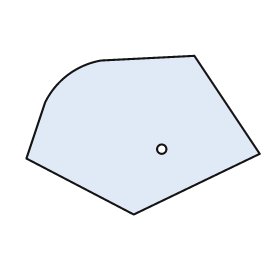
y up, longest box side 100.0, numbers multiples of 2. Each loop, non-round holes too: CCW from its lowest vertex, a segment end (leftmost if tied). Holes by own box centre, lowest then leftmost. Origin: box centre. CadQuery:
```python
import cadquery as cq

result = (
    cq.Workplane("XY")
    .moveTo(-4.0, -34.0)
    .lineTo(50.0, -8.0)
    .lineTo(22.0, 34.0)
    .lineTo(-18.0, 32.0)
    .threePointArc((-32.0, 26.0), (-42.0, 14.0))
    .lineTo(-50.0, -10.0)
    .close()
    .moveTo(8.0, -6.0)
    .circle(2.0)
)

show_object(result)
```